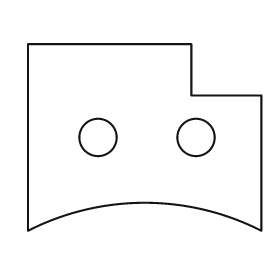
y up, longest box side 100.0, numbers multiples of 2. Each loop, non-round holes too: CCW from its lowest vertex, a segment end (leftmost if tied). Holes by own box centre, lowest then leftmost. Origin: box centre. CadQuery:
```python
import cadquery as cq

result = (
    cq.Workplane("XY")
    .moveTo(-50.0, -40.0)
    .threePointArc((0.0, -28.0), (50.0, -40.0))
    .lineTo(50.0, 18.0)
    .lineTo(20.0, 18.0)
    .lineTo(20.0, 40.0)
    .lineTo(-50.0, 40.0)
    .close()
    .moveTo(-20.0, 0.0)
    .circle(8.0)
    .moveTo(22.0, 0.0)
    .circle(8.0)
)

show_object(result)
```